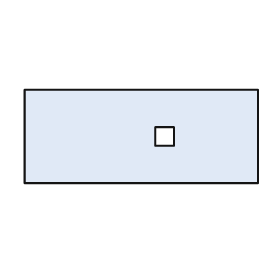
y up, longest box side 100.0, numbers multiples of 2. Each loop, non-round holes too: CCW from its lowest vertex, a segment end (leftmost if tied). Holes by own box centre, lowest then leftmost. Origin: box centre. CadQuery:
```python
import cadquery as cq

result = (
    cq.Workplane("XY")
    .moveTo(-50.0, -20.0)
    .lineTo(50.0, -20.0)
    .lineTo(50.0, 20.0)
    .lineTo(-50.0, 20.0)
    .close()
    .moveTo(6.0, -4.0)
    .lineTo(14.0, -4.0)
    .lineTo(14.0, 4.0)
    .lineTo(6.0, 4.0)
    .close()
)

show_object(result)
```